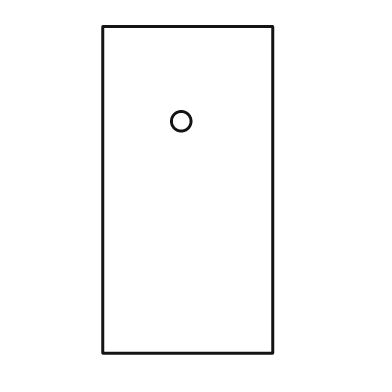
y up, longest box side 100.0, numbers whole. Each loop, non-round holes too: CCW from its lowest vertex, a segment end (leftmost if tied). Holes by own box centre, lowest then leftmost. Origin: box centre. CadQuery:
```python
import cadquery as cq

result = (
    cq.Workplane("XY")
    .moveTo(-26.0, -50.0)
    .lineTo(26.0, -50.0)
    .lineTo(26.0, 50.0)
    .lineTo(-26.0, 50.0)
    .close()
    .moveTo(-2.0, 21.0)
    .circle(3.0)
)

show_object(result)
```